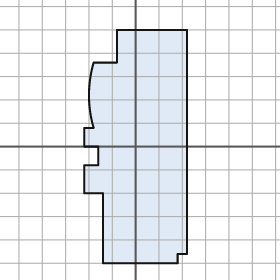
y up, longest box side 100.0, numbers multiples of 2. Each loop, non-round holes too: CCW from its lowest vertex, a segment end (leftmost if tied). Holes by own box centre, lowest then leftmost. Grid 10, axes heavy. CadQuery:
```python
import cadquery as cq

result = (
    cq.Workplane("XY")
    .moveTo(-14.0, -50.0)
    .lineTo(18.0, -50.0)
    .lineTo(18.0, -46.0)
    .lineTo(22.0, -46.0)
    .lineTo(22.0, 50.0)
    .lineTo(-8.0, 50.0)
    .lineTo(-8.0, 36.0)
    .lineTo(-18.0, 36.0)
    .threePointArc((-20.0, 22.0), (-18.0, 8.0))
    .lineTo(-22.0, 8.0)
    .lineTo(-22.0, 0.0)
    .lineTo(-16.0, 0.0)
    .lineTo(-16.0, -8.0)
    .lineTo(-22.0, -8.0)
    .lineTo(-22.0, -20.0)
    .lineTo(-14.0, -20.0)
    .close()
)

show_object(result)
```